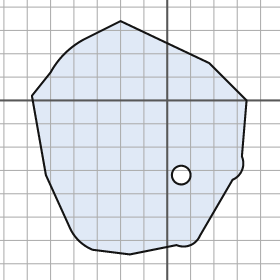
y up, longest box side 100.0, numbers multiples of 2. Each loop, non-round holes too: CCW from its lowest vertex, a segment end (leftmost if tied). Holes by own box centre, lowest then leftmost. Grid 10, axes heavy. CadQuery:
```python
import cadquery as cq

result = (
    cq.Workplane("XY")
    .moveTo(-16.0, -66.0)
    .lineTo(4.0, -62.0)
    .threePointArc((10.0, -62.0), (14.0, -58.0))
    .lineTo(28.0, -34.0)
    .threePointArc((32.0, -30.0), (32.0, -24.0))
    .lineTo(34.0, 0.0)
    .lineTo(18.0, 16.0)
    .lineTo(-20.0, 34.0)
    .lineTo(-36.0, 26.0)
    .threePointArc((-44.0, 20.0), (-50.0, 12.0))
    .lineTo(-58.0, 2.0)
    .lineTo(-52.0, -32.0)
    .lineTo(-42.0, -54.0)
    .threePointArc((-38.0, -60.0), (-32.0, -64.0))
    .close()
    .moveTo(6.0, -32.0)
    .circle(4.0)
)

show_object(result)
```